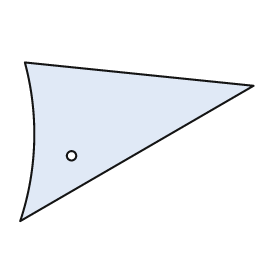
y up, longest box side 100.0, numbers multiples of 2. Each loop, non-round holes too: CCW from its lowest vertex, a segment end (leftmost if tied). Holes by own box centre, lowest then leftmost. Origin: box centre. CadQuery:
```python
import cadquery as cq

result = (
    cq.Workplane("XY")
    .moveTo(-50.0, -34.0)
    .lineTo(50.0, 24.0)
    .lineTo(-48.0, 34.0)
    .threePointArc((-44.0, 0.0), (-50.0, -34.0))
    .close()
    .moveTo(-28.0, -6.0)
    .circle(2.0)
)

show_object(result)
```